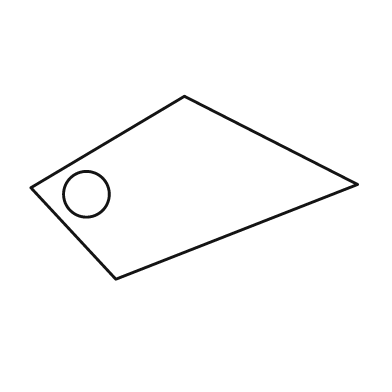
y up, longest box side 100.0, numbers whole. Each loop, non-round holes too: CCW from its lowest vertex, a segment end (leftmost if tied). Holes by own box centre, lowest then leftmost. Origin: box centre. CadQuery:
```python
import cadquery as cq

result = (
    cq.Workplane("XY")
    .moveTo(-24.0, -28.0)
    .lineTo(50.0, 1.0)
    .lineTo(-3.0, 28.0)
    .lineTo(-50.0, 0.0)
    .close()
    .moveTo(-33.0, -2.0)
    .circle(7.0)
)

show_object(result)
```